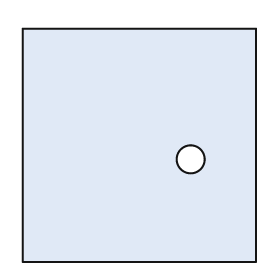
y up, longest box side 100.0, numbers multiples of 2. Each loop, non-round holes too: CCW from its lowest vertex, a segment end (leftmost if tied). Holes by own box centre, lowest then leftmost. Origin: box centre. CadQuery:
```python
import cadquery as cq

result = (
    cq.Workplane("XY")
    .moveTo(-50.0, -50.0)
    .lineTo(50.0, -50.0)
    .lineTo(50.0, 50.0)
    .lineTo(-50.0, 50.0)
    .close()
    .moveTo(22.0, -6.0)
    .circle(6.0)
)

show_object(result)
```